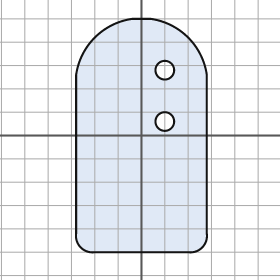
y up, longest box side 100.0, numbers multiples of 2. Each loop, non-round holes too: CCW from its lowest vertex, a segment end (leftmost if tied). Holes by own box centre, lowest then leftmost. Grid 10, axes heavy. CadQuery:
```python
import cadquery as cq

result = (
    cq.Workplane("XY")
    .moveTo(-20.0, -50.0)
    .lineTo(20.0, -50.0)
    .threePointArc((26.0, -48.0), (28.0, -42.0))
    .lineTo(28.0, 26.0)
    .threePointArc((20.0, 42.0), (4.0, 50.0))
    .lineTo(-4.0, 50.0)
    .threePointArc((-20.0, 42.0), (-28.0, 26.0))
    .lineTo(-28.0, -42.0)
    .threePointArc((-26.0, -48.0), (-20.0, -50.0))
    .close()
    .moveTo(10.0, 6.0)
    .circle(4.0)
    .moveTo(10.0, 28.0)
    .circle(4.0)
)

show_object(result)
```